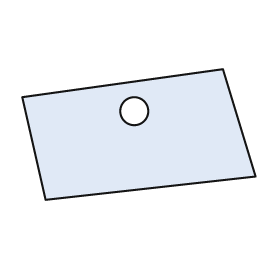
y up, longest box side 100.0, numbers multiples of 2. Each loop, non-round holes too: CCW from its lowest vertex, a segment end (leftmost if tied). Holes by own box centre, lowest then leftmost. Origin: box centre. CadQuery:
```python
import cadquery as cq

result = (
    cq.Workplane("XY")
    .moveTo(-40.0, -28.0)
    .lineTo(50.0, -18.0)
    .lineTo(36.0, 28.0)
    .lineTo(-50.0, 16.0)
    .close()
    .moveTo(-2.0, 10.0)
    .circle(6.0)
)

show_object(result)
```